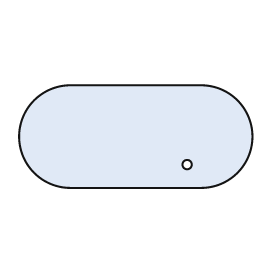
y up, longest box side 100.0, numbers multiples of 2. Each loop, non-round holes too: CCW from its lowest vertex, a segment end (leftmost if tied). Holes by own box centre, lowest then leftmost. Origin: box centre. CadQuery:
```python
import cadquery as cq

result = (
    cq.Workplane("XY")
    .moveTo(-28.0, -22.0)
    .lineTo(28.0, -22.0)
    .threePointArc((50.0, 0.0), (28.0, 22.0))
    .lineTo(-28.0, 22.0)
    .threePointArc((-50.0, 0.0), (-28.0, -22.0))
    .close()
    .moveTo(22.0, -12.0)
    .circle(2.0)
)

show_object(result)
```